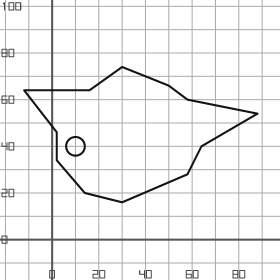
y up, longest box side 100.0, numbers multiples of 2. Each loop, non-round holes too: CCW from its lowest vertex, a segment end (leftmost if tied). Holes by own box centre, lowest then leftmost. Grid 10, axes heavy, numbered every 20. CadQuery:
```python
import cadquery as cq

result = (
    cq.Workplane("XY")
    .moveTo(30.0, 16.0)
    .lineTo(58.0, 28.0)
    .lineTo(64.0, 40.0)
    .lineTo(88.0, 54.0)
    .lineTo(58.0, 60.0)
    .lineTo(50.0, 66.0)
    .lineTo(30.0, 74.0)
    .lineTo(16.0, 64.0)
    .lineTo(-12.0, 64.0)
    .lineTo(2.0, 46.0)
    .lineTo(2.0, 34.0)
    .lineTo(14.0, 20.0)
    .close()
    .moveTo(10.0, 40.0)
    .circle(4.0)
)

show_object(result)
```